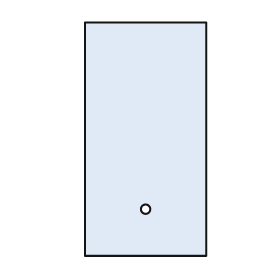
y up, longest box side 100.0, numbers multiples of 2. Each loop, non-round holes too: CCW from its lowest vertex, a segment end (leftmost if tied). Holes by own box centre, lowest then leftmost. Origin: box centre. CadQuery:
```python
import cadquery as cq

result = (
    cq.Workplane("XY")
    .moveTo(-26.0, -50.0)
    .lineTo(26.0, -50.0)
    .lineTo(26.0, 50.0)
    .lineTo(-26.0, 50.0)
    .close()
    .moveTo(0.0, -30.0)
    .circle(2.0)
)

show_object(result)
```